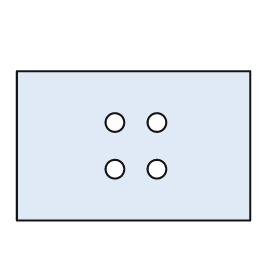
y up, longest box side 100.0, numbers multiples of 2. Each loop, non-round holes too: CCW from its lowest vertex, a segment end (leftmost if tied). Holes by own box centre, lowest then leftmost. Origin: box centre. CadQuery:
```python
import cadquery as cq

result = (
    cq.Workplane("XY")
    .moveTo(-50.0, -32.0)
    .lineTo(50.0, -32.0)
    .lineTo(50.0, 32.0)
    .lineTo(-50.0, 32.0)
    .close()
    .moveTo(-8.0, -10.0)
    .circle(4.0)
    .moveTo(10.0, -10.0)
    .circle(4.0)
    .moveTo(-8.0, 10.0)
    .circle(4.0)
    .moveTo(10.0, 10.0)
    .circle(4.0)
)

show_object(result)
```